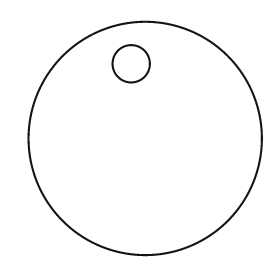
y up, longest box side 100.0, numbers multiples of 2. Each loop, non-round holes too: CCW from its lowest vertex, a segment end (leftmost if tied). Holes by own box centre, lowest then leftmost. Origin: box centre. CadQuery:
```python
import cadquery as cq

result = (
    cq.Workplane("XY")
    .moveTo(0.0, 0.0)
    .circle(50.0)
    .moveTo(-6.0, 32.0)
    .circle(8.0)
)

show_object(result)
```